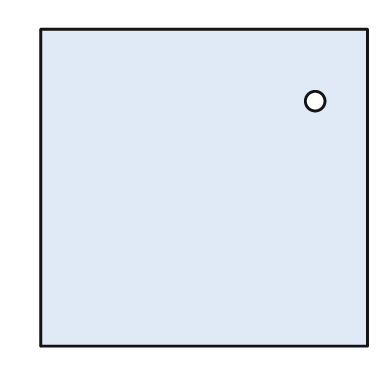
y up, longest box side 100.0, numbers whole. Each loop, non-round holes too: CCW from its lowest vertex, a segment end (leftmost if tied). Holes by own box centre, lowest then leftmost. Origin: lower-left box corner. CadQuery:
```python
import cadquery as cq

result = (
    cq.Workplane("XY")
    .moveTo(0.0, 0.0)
    .lineTo(100.0, 0.0)
    .lineTo(100.0, 97.0)
    .lineTo(0.0, 97.0)
    .close()
    .moveTo(84.0, 75.0)
    .circle(3.0)
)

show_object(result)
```